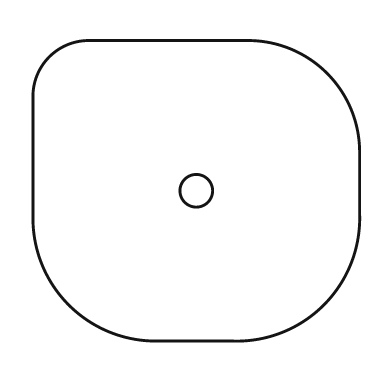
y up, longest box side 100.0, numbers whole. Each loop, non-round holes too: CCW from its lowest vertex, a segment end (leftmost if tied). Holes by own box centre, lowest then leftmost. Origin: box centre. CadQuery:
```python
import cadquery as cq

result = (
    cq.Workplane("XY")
    .moveTo(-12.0, -46.0)
    .lineTo(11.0, -46.0)
    .threePointArc((39.0, -35.0), (50.0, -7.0))
    .lineTo(50.0, 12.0)
    .threePointArc((40.0, 36.0), (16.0, 46.0))
    .lineTo(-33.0, 46.0)
    .threePointArc((-45.0, 41.0), (-50.0, 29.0))
    .lineTo(-50.0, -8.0)
    .threePointArc((-39.0, -35.0), (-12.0, -46.0))
    .close()
    .moveTo(0.0, 0.0)
    .circle(5.0)
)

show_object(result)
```